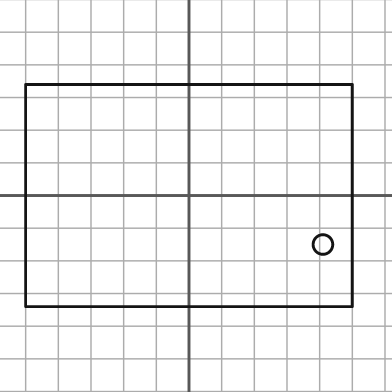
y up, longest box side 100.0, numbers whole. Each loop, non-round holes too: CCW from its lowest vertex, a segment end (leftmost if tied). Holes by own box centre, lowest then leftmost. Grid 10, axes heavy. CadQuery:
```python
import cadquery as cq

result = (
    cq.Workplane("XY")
    .moveTo(-50.0, -34.0)
    .lineTo(50.0, -34.0)
    .lineTo(50.0, 34.0)
    .lineTo(-50.0, 34.0)
    .close()
    .moveTo(41.0, -15.0)
    .circle(3.0)
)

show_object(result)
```